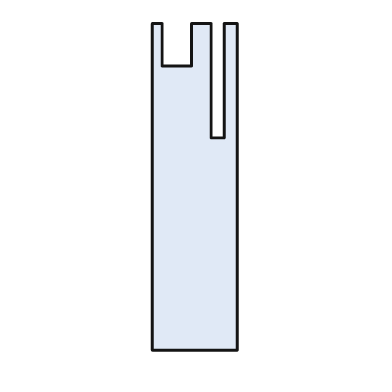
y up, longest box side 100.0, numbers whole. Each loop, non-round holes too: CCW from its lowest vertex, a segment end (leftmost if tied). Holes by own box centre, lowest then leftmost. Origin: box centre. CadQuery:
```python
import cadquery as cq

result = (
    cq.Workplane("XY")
    .moveTo(-13.0, -50.0)
    .lineTo(13.0, -50.0)
    .lineTo(13.0, 50.0)
    .lineTo(9.0, 50.0)
    .lineTo(9.0, 15.0)
    .lineTo(5.0, 15.0)
    .lineTo(5.0, 50.0)
    .lineTo(-1.0, 50.0)
    .lineTo(-1.0, 37.0)
    .lineTo(-10.0, 37.0)
    .lineTo(-10.0, 50.0)
    .lineTo(-13.0, 50.0)
    .close()
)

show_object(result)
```